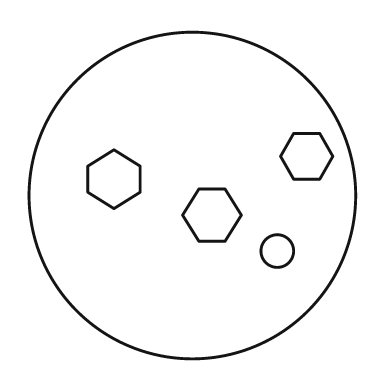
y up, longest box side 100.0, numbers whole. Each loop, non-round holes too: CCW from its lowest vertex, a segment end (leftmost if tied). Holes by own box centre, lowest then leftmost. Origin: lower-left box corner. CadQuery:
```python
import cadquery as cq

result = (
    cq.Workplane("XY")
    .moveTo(50.0, 50.0)
    .circle(50.0)
    .moveTo(76.0, 33.0)
    .circle(5.0)
    .moveTo(52.0, 36.0)
    .lineTo(60.0, 36.0)
    .lineTo(65.0, 44.0)
    .lineTo(60.0, 52.0)
    .lineTo(52.0, 52.0)
    .lineTo(47.0, 44.0)
    .close()
    .moveTo(26.0, 46.0)
    .lineTo(34.0, 51.0)
    .lineTo(34.0, 59.0)
    .lineTo(26.0, 64.0)
    .lineTo(18.0, 59.0)
    .lineTo(18.0, 51.0)
    .close()
    .moveTo(81.0, 55.0)
    .lineTo(89.0, 55.0)
    .lineTo(93.0, 62.0)
    .lineTo(89.0, 69.0)
    .lineTo(81.0, 69.0)
    .lineTo(77.0, 62.0)
    .close()
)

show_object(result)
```